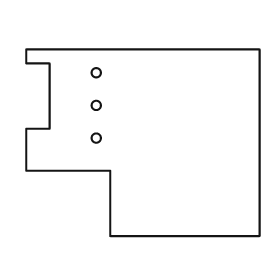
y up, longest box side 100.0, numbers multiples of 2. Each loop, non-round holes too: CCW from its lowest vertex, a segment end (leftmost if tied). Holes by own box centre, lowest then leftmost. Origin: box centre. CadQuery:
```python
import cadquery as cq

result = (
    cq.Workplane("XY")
    .moveTo(-14.0, -40.0)
    .lineTo(50.0, -40.0)
    .lineTo(50.0, 40.0)
    .lineTo(-50.0, 40.0)
    .lineTo(-50.0, 34.0)
    .lineTo(-40.0, 34.0)
    .lineTo(-40.0, 6.0)
    .lineTo(-50.0, 6.0)
    .lineTo(-50.0, -12.0)
    .lineTo(-14.0, -12.0)
    .close()
    .moveTo(-20.0, 2.0)
    .circle(2.0)
    .moveTo(-20.0, 16.0)
    .circle(2.0)
    .moveTo(-20.0, 30.0)
    .circle(2.0)
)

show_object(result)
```